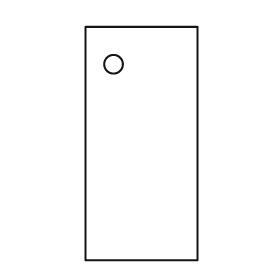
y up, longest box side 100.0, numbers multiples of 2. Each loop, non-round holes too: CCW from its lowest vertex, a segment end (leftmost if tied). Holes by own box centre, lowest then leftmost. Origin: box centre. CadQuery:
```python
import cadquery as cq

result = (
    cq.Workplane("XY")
    .moveTo(-24.0, -50.0)
    .lineTo(24.0, -50.0)
    .lineTo(24.0, 50.0)
    .lineTo(-24.0, 50.0)
    .close()
    .moveTo(-12.0, 34.0)
    .circle(4.0)
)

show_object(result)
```